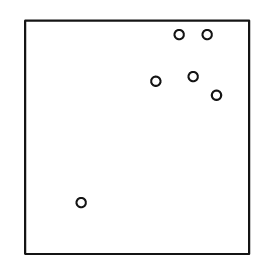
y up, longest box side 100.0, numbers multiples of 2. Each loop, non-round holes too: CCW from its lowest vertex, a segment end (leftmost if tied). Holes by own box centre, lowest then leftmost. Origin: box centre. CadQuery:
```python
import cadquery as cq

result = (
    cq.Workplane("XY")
    .moveTo(-48.0, -50.0)
    .lineTo(48.0, -50.0)
    .lineTo(48.0, 50.0)
    .lineTo(-48.0, 50.0)
    .close()
    .moveTo(-24.0, -28.0)
    .circle(2.0)
    .moveTo(34.0, 18.0)
    .circle(2.0)
    .moveTo(8.0, 24.0)
    .circle(2.0)
    .moveTo(24.0, 26.0)
    .circle(2.0)
    .moveTo(18.0, 44.0)
    .circle(2.0)
    .moveTo(30.0, 44.0)
    .circle(2.0)
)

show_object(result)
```